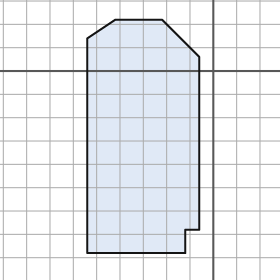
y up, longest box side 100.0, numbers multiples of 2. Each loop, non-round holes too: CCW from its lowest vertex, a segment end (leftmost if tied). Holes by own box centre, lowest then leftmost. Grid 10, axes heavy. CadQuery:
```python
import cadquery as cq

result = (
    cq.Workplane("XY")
    .moveTo(-54.0, -78.0)
    .lineTo(-12.0, -78.0)
    .lineTo(-12.0, -68.0)
    .lineTo(-6.0, -68.0)
    .lineTo(-6.0, 6.0)
    .lineTo(-22.0, 22.0)
    .lineTo(-42.0, 22.0)
    .lineTo(-54.0, 14.0)
    .close()
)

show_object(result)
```